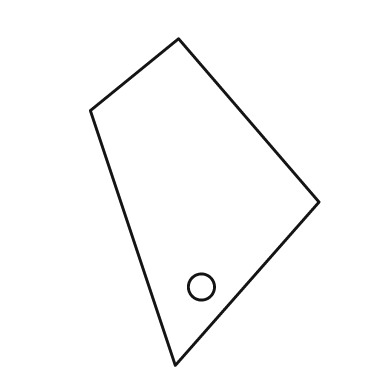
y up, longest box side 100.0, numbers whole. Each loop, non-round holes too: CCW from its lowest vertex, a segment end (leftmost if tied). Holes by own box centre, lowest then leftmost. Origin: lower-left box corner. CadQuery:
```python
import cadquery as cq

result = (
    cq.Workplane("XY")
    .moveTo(26.0, 0.0)
    .lineTo(70.0, 50.0)
    .lineTo(27.0, 100.0)
    .lineTo(0.0, 78.0)
    .close()
    .moveTo(34.0, 24.0)
    .circle(4.0)
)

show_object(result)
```